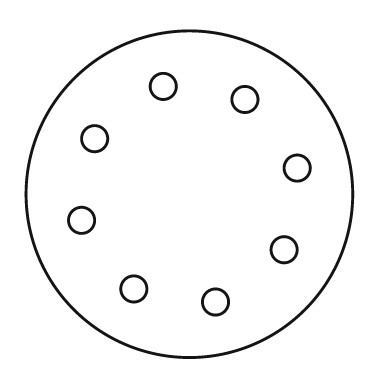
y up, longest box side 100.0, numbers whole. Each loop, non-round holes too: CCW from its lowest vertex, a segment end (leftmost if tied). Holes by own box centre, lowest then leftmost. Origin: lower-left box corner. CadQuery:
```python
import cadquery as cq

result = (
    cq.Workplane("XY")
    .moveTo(50.0, 50.0)
    .circle(50.0)
    .moveTo(58.0, 17.0)
    .circle(4.0)
    .moveTo(33.0, 21.0)
    .circle(4.0)
    .moveTo(79.0, 33.0)
    .circle(4.0)
    .moveTo(17.0, 42.0)
    .circle(4.0)
    .moveTo(83.0, 58.0)
    .circle(4.0)
    .moveTo(21.0, 67.0)
    .circle(4.0)
    .moveTo(67.0, 79.0)
    .circle(4.0)
    .moveTo(42.0, 83.0)
    .circle(4.0)
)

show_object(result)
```